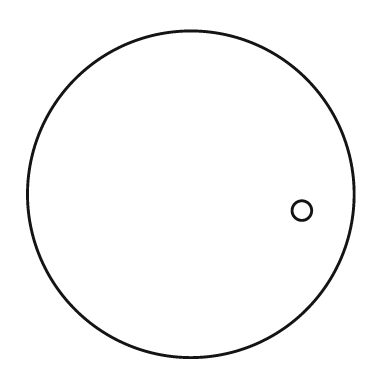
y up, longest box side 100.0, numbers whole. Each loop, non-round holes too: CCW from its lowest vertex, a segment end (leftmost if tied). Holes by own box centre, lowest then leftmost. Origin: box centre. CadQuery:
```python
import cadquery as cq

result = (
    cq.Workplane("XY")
    .moveTo(0.0, 0.0)
    .circle(50.0)
    .moveTo(34.0, -5.0)
    .circle(3.0)
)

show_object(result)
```